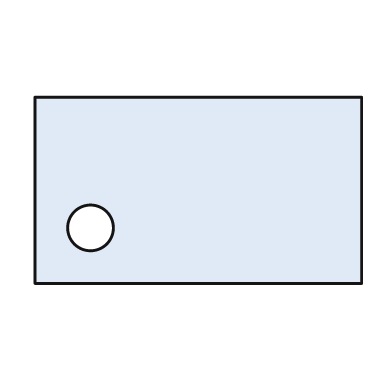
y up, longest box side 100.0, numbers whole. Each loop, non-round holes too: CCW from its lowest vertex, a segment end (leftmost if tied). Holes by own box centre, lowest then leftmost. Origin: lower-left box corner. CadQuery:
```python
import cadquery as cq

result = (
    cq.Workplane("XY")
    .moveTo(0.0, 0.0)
    .lineTo(100.0, 0.0)
    .lineTo(100.0, 57.0)
    .lineTo(0.0, 57.0)
    .close()
    .moveTo(17.0, 17.0)
    .circle(7.0)
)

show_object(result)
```